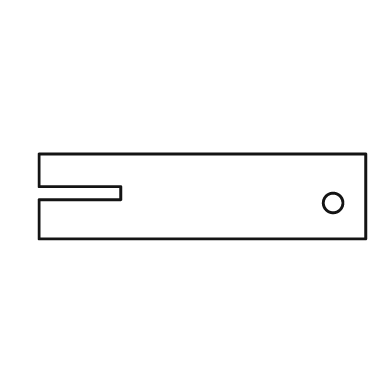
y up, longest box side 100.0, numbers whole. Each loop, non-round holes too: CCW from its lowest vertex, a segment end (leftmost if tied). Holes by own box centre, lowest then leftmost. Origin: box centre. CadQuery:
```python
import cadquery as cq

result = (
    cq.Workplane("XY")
    .moveTo(-50.0, -13.0)
    .lineTo(50.0, -13.0)
    .lineTo(50.0, 13.0)
    .lineTo(-50.0, 13.0)
    .lineTo(-50.0, 3.0)
    .lineTo(-25.0, 3.0)
    .lineTo(-25.0, -1.0)
    .lineTo(-50.0, -1.0)
    .close()
    .moveTo(40.0, -2.0)
    .circle(3.0)
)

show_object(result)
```